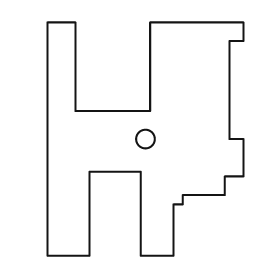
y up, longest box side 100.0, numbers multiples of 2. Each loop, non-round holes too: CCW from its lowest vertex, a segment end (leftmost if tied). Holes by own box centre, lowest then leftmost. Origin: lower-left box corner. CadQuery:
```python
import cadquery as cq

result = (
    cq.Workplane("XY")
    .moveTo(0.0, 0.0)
    .lineTo(18.0, 0.0)
    .lineTo(18.0, 36.0)
    .lineTo(40.0, 36.0)
    .lineTo(40.0, 0.0)
    .lineTo(54.0, 0.0)
    .lineTo(54.0, 22.0)
    .lineTo(58.0, 22.0)
    .lineTo(58.0, 26.0)
    .lineTo(76.0, 26.0)
    .lineTo(76.0, 34.0)
    .lineTo(84.0, 34.0)
    .lineTo(84.0, 50.0)
    .lineTo(78.0, 50.0)
    .lineTo(78.0, 92.0)
    .lineTo(84.0, 92.0)
    .lineTo(84.0, 100.0)
    .lineTo(44.0, 100.0)
    .lineTo(44.0, 62.0)
    .lineTo(12.0, 62.0)
    .lineTo(12.0, 100.0)
    .lineTo(0.0, 100.0)
    .close()
    .moveTo(42.0, 50.0)
    .circle(4.0)
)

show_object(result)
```